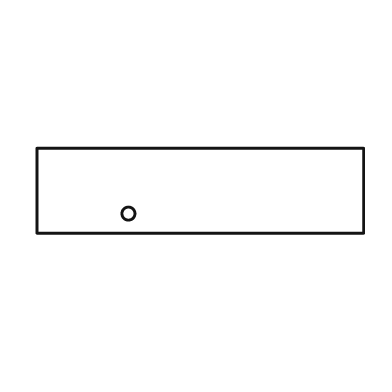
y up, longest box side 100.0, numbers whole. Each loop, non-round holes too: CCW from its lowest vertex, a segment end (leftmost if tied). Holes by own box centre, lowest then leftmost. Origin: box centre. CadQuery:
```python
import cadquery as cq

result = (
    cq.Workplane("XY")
    .moveTo(-50.0, -13.0)
    .lineTo(50.0, -13.0)
    .lineTo(50.0, 13.0)
    .lineTo(-50.0, 13.0)
    .close()
    .moveTo(-22.0, -7.0)
    .circle(2.0)
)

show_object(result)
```